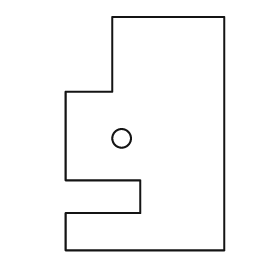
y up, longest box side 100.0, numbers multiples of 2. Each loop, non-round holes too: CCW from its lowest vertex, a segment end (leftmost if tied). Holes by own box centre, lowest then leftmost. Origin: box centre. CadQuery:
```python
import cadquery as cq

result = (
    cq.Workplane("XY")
    .moveTo(-34.0, -50.0)
    .lineTo(34.0, -50.0)
    .lineTo(34.0, 50.0)
    .lineTo(-14.0, 50.0)
    .lineTo(-14.0, 18.0)
    .lineTo(-34.0, 18.0)
    .lineTo(-34.0, -20.0)
    .lineTo(-2.0, -20.0)
    .lineTo(-2.0, -34.0)
    .lineTo(-34.0, -34.0)
    .close()
    .moveTo(-10.0, -2.0)
    .circle(4.0)
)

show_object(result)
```